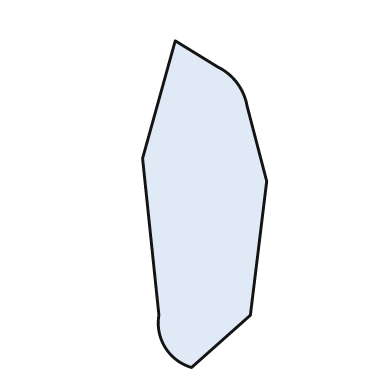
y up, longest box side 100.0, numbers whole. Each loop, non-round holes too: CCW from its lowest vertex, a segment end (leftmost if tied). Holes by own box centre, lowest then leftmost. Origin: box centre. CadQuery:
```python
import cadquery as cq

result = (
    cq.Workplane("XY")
    .moveTo(-4.0, -50.0)
    .lineTo(14.0, -34.0)
    .lineTo(19.0, 7.0)
    .lineTo(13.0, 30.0)
    .threePointArc((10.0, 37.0), (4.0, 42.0))
    .lineTo(-9.0, 50.0)
    .lineTo(-19.0, 14.0)
    .lineTo(-14.0, -34.0)
    .threePointArc((-12.0, -44.0), (-4.0, -50.0))
    .close()
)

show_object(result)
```